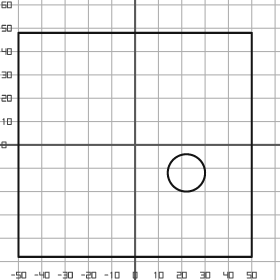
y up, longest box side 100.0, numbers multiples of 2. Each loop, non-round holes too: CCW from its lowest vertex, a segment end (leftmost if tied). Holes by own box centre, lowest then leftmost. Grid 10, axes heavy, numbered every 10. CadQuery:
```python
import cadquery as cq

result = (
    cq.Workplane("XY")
    .moveTo(-50.0, -48.0)
    .lineTo(50.0, -48.0)
    .lineTo(50.0, 48.0)
    .lineTo(-50.0, 48.0)
    .close()
    .moveTo(22.0, -12.0)
    .circle(8.0)
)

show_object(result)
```